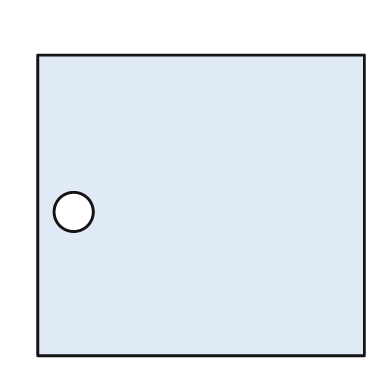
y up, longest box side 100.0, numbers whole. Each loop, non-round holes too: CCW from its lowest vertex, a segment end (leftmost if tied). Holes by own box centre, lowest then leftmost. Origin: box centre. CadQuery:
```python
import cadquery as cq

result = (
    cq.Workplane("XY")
    .moveTo(-50.0, -46.0)
    .lineTo(50.0, -46.0)
    .lineTo(50.0, 46.0)
    .lineTo(-50.0, 46.0)
    .close()
    .moveTo(-39.0, -2.0)
    .circle(6.0)
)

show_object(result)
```